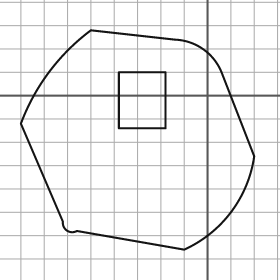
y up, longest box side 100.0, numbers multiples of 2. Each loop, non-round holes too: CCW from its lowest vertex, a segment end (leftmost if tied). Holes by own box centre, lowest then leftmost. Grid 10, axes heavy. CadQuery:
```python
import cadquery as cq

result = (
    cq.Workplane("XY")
    .moveTo(-10.0, -66.0)
    .threePointArc((10.0, -50.0), (20.0, -26.0))
    .lineTo(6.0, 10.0)
    .threePointArc((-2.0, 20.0), (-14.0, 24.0))
    .lineTo(-50.0, 28.0)
    .threePointArc((-68.0, 10.0), (-80.0, -12.0))
    .lineTo(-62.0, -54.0)
    .threePointArc((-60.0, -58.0), (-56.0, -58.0))
    .close()
    .moveTo(-38.0, -14.0)
    .lineTo(-18.0, -14.0)
    .lineTo(-18.0, 10.0)
    .lineTo(-38.0, 10.0)
    .close()
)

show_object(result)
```